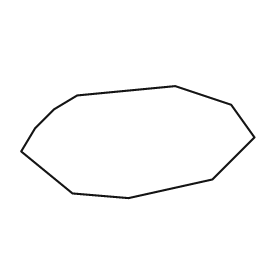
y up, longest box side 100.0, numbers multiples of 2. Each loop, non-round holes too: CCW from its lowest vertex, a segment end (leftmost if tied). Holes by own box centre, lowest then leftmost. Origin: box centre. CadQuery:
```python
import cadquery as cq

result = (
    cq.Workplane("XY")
    .moveTo(-4.0, -24.0)
    .lineTo(32.0, -16.0)
    .lineTo(50.0, 2.0)
    .lineTo(40.0, 16.0)
    .lineTo(16.0, 24.0)
    .lineTo(-26.0, 20.0)
    .lineTo(-36.0, 14.0)
    .lineTo(-44.0, 6.0)
    .lineTo(-50.0, -4.0)
    .lineTo(-28.0, -22.0)
    .close()
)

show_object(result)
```